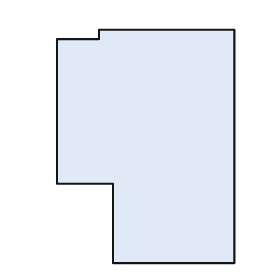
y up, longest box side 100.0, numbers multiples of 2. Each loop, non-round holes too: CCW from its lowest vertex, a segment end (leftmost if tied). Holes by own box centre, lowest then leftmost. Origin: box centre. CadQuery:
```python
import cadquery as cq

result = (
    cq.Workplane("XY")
    .moveTo(-14.0, -50.0)
    .lineTo(38.0, -50.0)
    .lineTo(38.0, 50.0)
    .lineTo(-20.0, 50.0)
    .lineTo(-20.0, 46.0)
    .lineTo(-38.0, 46.0)
    .lineTo(-38.0, -16.0)
    .lineTo(-14.0, -16.0)
    .close()
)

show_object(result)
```